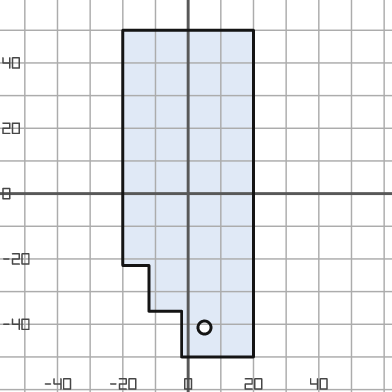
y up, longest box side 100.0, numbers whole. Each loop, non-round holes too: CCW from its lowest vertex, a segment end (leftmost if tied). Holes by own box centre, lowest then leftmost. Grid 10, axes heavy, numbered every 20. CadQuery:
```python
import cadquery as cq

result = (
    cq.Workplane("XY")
    .moveTo(-2.0, -50.0)
    .lineTo(20.0, -50.0)
    .lineTo(20.0, 50.0)
    .lineTo(-20.0, 50.0)
    .lineTo(-20.0, -22.0)
    .lineTo(-12.0, -22.0)
    .lineTo(-12.0, -36.0)
    .lineTo(-2.0, -36.0)
    .close()
    .moveTo(5.0, -41.0)
    .circle(2.0)
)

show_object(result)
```